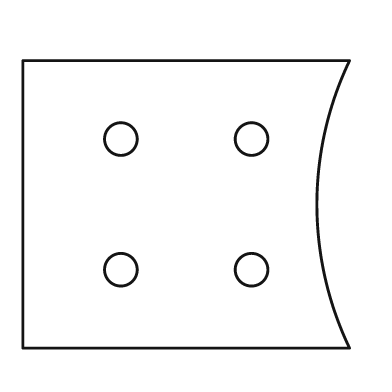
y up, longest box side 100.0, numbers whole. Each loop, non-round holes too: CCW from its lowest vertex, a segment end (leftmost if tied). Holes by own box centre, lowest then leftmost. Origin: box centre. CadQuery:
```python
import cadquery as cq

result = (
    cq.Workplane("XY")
    .moveTo(-50.0, -44.0)
    .lineTo(50.0, -44.0)
    .threePointArc((40.0, 0.0), (50.0, 44.0))
    .lineTo(-50.0, 44.0)
    .close()
    .moveTo(-20.0, -20.0)
    .circle(5.0)
    .moveTo(20.0, -20.0)
    .circle(5.0)
    .moveTo(-20.0, 20.0)
    .circle(5.0)
    .moveTo(20.0, 20.0)
    .circle(5.0)
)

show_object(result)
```